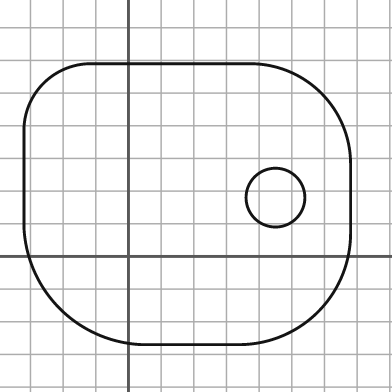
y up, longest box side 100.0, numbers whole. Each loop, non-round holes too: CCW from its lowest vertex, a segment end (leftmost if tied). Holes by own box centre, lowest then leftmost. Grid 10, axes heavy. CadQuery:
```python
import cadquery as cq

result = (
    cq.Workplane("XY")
    .moveTo(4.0, -27.0)
    .lineTo(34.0, -27.0)
    .threePointArc((58.0, -17.0), (68.0, 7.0))
    .lineTo(68.0, 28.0)
    .threePointArc((59.0, 50.0), (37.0, 59.0))
    .lineTo(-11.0, 59.0)
    .threePointArc((-26.0, 53.0), (-32.0, 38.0))
    .lineTo(-32.0, 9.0)
    .threePointArc((-21.0, -16.0), (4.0, -27.0))
    .close()
    .moveTo(45.0, 18.0)
    .circle(9.0)
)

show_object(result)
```